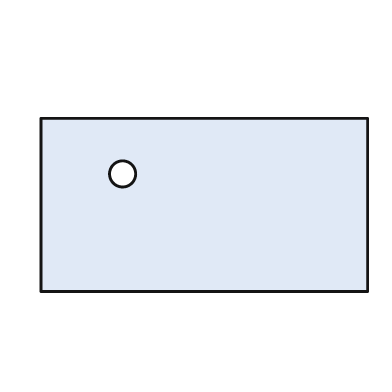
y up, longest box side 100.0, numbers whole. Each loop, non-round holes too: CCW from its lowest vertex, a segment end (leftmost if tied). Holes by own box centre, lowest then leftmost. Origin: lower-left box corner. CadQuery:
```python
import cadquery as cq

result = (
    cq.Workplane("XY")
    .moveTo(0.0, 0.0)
    .lineTo(100.0, 0.0)
    .lineTo(100.0, 53.0)
    .lineTo(0.0, 53.0)
    .close()
    .moveTo(25.0, 36.0)
    .circle(4.0)
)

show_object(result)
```